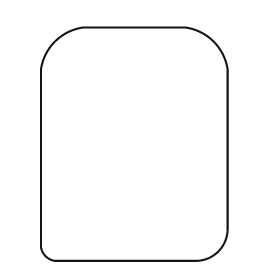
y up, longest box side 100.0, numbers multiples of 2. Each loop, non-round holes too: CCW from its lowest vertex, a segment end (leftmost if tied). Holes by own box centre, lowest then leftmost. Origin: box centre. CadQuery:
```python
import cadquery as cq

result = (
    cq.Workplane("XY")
    .moveTo(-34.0, -50.0)
    .lineTo(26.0, -50.0)
    .threePointArc((36.0, -46.0), (40.0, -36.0))
    .lineTo(40.0, 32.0)
    .threePointArc((34.0, 44.0), (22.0, 50.0))
    .lineTo(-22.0, 50.0)
    .threePointArc((-34.0, 44.0), (-40.0, 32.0))
    .lineTo(-40.0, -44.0)
    .threePointArc((-38.0, -48.0), (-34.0, -50.0))
    .close()
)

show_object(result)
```